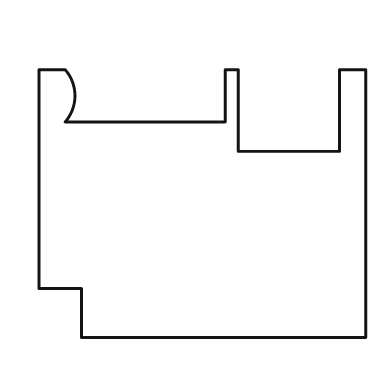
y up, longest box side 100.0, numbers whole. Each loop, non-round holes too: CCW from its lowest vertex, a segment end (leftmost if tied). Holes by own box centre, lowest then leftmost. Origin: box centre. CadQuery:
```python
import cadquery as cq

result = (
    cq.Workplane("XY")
    .moveTo(-37.0, -41.0)
    .lineTo(50.0, -41.0)
    .lineTo(50.0, 41.0)
    .lineTo(42.0, 41.0)
    .lineTo(42.0, 16.0)
    .lineTo(11.0, 16.0)
    .lineTo(11.0, 41.0)
    .lineTo(7.0, 41.0)
    .lineTo(7.0, 25.0)
    .lineTo(-42.0, 25.0)
    .threePointArc((-39.0, 33.0), (-42.0, 41.0))
    .lineTo(-50.0, 41.0)
    .lineTo(-50.0, -26.0)
    .lineTo(-37.0, -26.0)
    .close()
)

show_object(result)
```